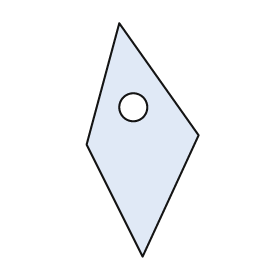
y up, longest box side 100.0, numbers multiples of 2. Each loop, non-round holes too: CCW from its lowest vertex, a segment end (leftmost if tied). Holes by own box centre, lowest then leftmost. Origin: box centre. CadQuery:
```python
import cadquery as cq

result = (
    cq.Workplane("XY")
    .moveTo(0.0, -50.0)
    .lineTo(24.0, 2.0)
    .lineTo(-10.0, 50.0)
    .lineTo(-24.0, -2.0)
    .close()
    .moveTo(-4.0, 14.0)
    .circle(6.0)
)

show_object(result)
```